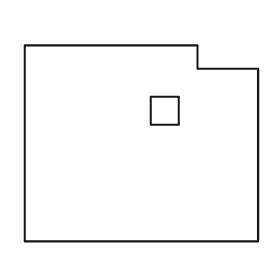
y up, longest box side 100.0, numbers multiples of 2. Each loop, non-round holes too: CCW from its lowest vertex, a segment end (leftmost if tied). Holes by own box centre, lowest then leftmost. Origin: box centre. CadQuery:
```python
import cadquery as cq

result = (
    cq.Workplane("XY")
    .moveTo(-50.0, -42.0)
    .lineTo(50.0, -42.0)
    .lineTo(50.0, 32.0)
    .lineTo(24.0, 32.0)
    .lineTo(24.0, 42.0)
    .lineTo(-50.0, 42.0)
    .close()
    .moveTo(4.0, 8.0)
    .lineTo(16.0, 8.0)
    .lineTo(16.0, 20.0)
    .lineTo(4.0, 20.0)
    .close()
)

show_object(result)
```